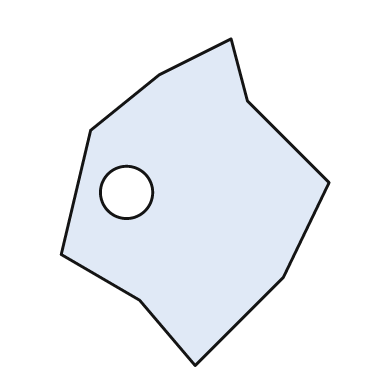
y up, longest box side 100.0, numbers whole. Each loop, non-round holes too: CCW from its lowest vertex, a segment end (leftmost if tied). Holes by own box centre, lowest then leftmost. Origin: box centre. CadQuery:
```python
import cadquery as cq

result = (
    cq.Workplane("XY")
    .moveTo(0.0, -50.0)
    .lineTo(27.0, -23.0)
    .lineTo(41.0, 6.0)
    .lineTo(16.0, 31.0)
    .lineTo(11.0, 50.0)
    .lineTo(-11.0, 39.0)
    .lineTo(-32.0, 22.0)
    .lineTo(-41.0, -16.0)
    .lineTo(-17.0, -30.0)
    .close()
    .moveTo(-21.0, 3.0)
    .circle(8.0)
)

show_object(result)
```